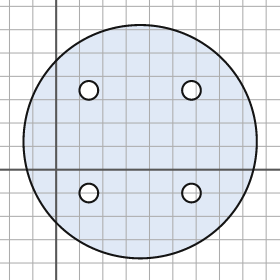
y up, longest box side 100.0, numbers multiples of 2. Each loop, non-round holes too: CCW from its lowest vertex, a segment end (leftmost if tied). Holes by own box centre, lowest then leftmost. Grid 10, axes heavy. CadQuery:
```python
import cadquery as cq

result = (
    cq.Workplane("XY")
    .moveTo(36.0, 12.0)
    .circle(50.0)
    .moveTo(14.0, -10.0)
    .circle(4.0)
    .moveTo(58.0, -10.0)
    .circle(4.0)
    .moveTo(14.0, 34.0)
    .circle(4.0)
    .moveTo(58.0, 34.0)
    .circle(4.0)
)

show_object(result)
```